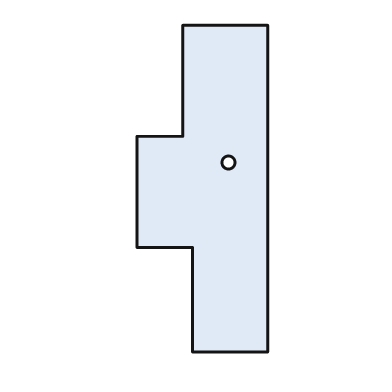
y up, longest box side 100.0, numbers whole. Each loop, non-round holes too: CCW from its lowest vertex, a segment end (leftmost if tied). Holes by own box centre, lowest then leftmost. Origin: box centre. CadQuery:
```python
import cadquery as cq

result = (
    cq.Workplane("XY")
    .moveTo(-3.0, -50.0)
    .lineTo(20.0, -50.0)
    .lineTo(20.0, 50.0)
    .lineTo(-6.0, 50.0)
    .lineTo(-6.0, 16.0)
    .lineTo(-20.0, 16.0)
    .lineTo(-20.0, -18.0)
    .lineTo(-3.0, -18.0)
    .close()
    .moveTo(8.0, 8.0)
    .circle(2.0)
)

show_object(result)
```